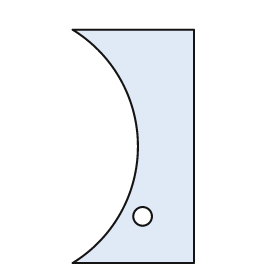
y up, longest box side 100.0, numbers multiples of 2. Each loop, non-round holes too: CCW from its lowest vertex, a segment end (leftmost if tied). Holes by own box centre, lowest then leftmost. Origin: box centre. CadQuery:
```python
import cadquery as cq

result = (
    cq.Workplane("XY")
    .moveTo(-26.0, -50.0)
    .lineTo(26.0, -50.0)
    .lineTo(26.0, 50.0)
    .lineTo(-26.0, 50.0)
    .threePointArc((2.0, 0.0), (-26.0, -50.0))
    .close()
    .moveTo(4.0, -30.0)
    .circle(4.0)
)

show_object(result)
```